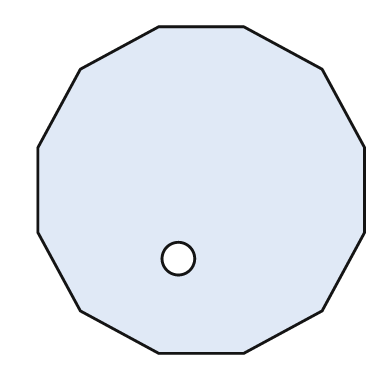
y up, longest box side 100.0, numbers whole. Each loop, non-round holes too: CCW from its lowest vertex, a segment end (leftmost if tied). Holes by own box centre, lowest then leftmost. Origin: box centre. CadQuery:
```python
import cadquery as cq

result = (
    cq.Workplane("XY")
    .moveTo(-13.0, -50.0)
    .lineTo(13.0, -50.0)
    .lineTo(37.0, -37.0)
    .lineTo(50.0, -13.0)
    .lineTo(50.0, 13.0)
    .lineTo(37.0, 37.0)
    .lineTo(13.0, 50.0)
    .lineTo(-13.0, 50.0)
    .lineTo(-37.0, 37.0)
    .lineTo(-50.0, 13.0)
    .lineTo(-50.0, -13.0)
    .lineTo(-37.0, -37.0)
    .close()
    .moveTo(-7.0, -21.0)
    .circle(5.0)
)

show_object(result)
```